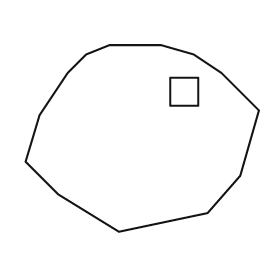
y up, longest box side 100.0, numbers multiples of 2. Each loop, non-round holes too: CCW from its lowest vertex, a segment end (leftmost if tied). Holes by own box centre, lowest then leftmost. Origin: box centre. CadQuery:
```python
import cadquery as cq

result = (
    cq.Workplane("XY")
    .moveTo(-10.0, -40.0)
    .lineTo(28.0, -32.0)
    .lineTo(42.0, -16.0)
    .lineTo(50.0, 12.0)
    .lineTo(34.0, 28.0)
    .lineTo(22.0, 36.0)
    .lineTo(8.0, 40.0)
    .lineTo(-14.0, 40.0)
    .lineTo(-24.0, 36.0)
    .lineTo(-32.0, 28.0)
    .lineTo(-44.0, 10.0)
    .lineTo(-50.0, -10.0)
    .lineTo(-36.0, -24.0)
    .close()
    .moveTo(12.0, 14.0)
    .lineTo(24.0, 14.0)
    .lineTo(24.0, 26.0)
    .lineTo(12.0, 26.0)
    .close()
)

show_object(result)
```